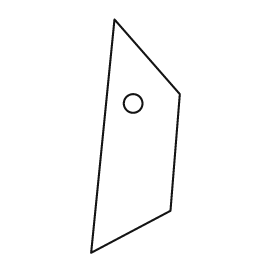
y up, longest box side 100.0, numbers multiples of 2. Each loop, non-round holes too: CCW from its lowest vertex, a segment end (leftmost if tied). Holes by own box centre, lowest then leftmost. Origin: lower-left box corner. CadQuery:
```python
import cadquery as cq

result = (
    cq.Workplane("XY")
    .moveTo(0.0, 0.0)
    .lineTo(34.0, 18.0)
    .lineTo(38.0, 68.0)
    .lineTo(10.0, 100.0)
    .close()
    .moveTo(18.0, 64.0)
    .circle(4.0)
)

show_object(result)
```